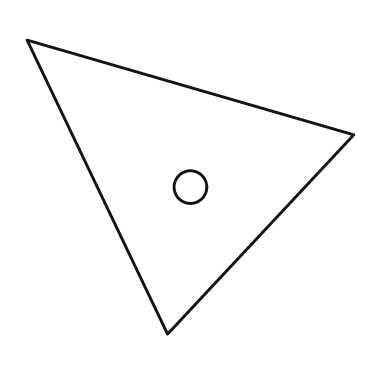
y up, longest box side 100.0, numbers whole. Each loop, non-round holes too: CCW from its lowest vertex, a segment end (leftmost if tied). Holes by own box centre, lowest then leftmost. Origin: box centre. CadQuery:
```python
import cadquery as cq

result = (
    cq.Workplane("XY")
    .moveTo(-7.0, -45.0)
    .lineTo(50.0, 16.0)
    .lineTo(-50.0, 45.0)
    .close()
    .moveTo(0.0, 0.0)
    .circle(5.0)
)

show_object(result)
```